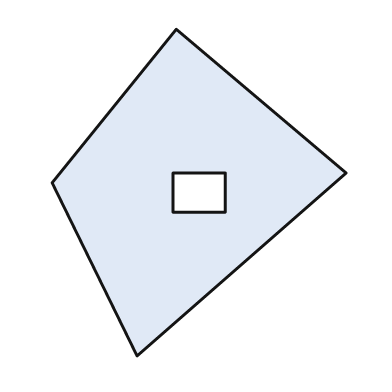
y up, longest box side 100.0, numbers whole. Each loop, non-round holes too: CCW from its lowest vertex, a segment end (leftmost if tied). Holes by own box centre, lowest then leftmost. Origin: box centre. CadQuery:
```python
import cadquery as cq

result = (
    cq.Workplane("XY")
    .moveTo(-19.0, -50.0)
    .lineTo(45.0, 6.0)
    .lineTo(-7.0, 50.0)
    .lineTo(-45.0, 3.0)
    .close()
    .moveTo(-8.0, -6.0)
    .lineTo(8.0, -6.0)
    .lineTo(8.0, 6.0)
    .lineTo(-8.0, 6.0)
    .close()
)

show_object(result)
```